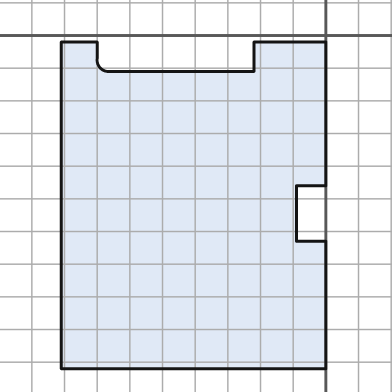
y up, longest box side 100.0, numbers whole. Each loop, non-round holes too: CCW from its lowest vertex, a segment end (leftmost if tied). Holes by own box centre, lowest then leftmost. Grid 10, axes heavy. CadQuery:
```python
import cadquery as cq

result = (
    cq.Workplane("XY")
    .moveTo(-81.0, -102.0)
    .lineTo(0.0, -102.0)
    .lineTo(0.0, -63.0)
    .lineTo(-9.0, -63.0)
    .lineTo(-9.0, -46.0)
    .lineTo(0.0, -46.0)
    .lineTo(0.0, -2.0)
    .lineTo(-22.0, -2.0)
    .lineTo(-22.0, -11.0)
    .lineTo(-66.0, -11.0)
    .threePointArc((-69.0, -10.0), (-70.0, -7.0))
    .lineTo(-70.0, -2.0)
    .lineTo(-81.0, -2.0)
    .close()
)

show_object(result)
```